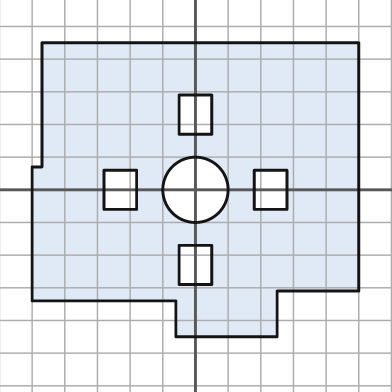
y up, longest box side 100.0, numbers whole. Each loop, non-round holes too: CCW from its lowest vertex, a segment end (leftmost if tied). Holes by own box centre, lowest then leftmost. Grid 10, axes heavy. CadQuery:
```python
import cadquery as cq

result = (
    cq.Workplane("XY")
    .moveTo(-6.0, -45.0)
    .lineTo(25.0, -45.0)
    .lineTo(25.0, -31.0)
    .lineTo(50.0, -31.0)
    .lineTo(50.0, 45.0)
    .lineTo(-47.0, 45.0)
    .lineTo(-47.0, 7.0)
    .lineTo(-50.0, 7.0)
    .lineTo(-50.0, -34.0)
    .lineTo(-6.0, -34.0)
    .close()
    .moveTo(-5.0, -29.0)
    .lineTo(5.0, -29.0)
    .lineTo(5.0, -17.0)
    .lineTo(-5.0, -17.0)
    .close()
    .moveTo(-28.0, -6.0)
    .lineTo(-18.0, -6.0)
    .lineTo(-18.0, 6.0)
    .lineTo(-28.0, 6.0)
    .close()
    .moveTo(0.0, 0.0)
    .circle(10.0)
    .moveTo(18.0, -6.0)
    .lineTo(28.0, -6.0)
    .lineTo(28.0, 6.0)
    .lineTo(18.0, 6.0)
    .close()
    .moveTo(-5.0, 17.0)
    .lineTo(5.0, 17.0)
    .lineTo(5.0, 29.0)
    .lineTo(-5.0, 29.0)
    .close()
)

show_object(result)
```